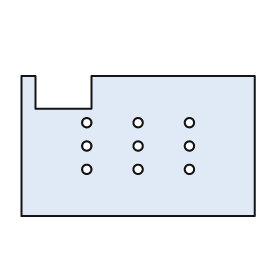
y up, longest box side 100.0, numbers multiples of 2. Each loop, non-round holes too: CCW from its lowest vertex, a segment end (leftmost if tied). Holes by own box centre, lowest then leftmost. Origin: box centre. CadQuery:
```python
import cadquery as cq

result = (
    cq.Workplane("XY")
    .moveTo(-50.0, -30.0)
    .lineTo(50.0, -30.0)
    .lineTo(50.0, 30.0)
    .lineTo(-20.0, 30.0)
    .lineTo(-20.0, 16.0)
    .lineTo(-44.0, 16.0)
    .lineTo(-44.0, 30.0)
    .lineTo(-50.0, 30.0)
    .close()
    .moveTo(-22.0, -10.0)
    .circle(2.0)
    .moveTo(0.0, -10.0)
    .circle(2.0)
    .moveTo(22.0, -10.0)
    .circle(2.0)
    .moveTo(-22.0, 0.0)
    .circle(2.0)
    .moveTo(0.0, 0.0)
    .circle(2.0)
    .moveTo(22.0, 0.0)
    .circle(2.0)
    .moveTo(-22.0, 10.0)
    .circle(2.0)
    .moveTo(0.0, 10.0)
    .circle(2.0)
    .moveTo(22.0, 10.0)
    .circle(2.0)
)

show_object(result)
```